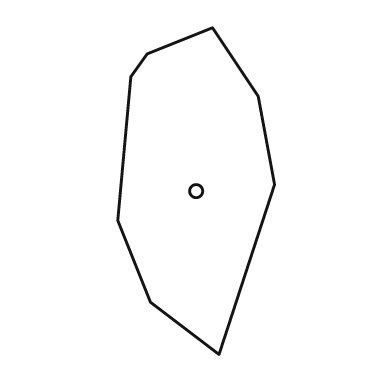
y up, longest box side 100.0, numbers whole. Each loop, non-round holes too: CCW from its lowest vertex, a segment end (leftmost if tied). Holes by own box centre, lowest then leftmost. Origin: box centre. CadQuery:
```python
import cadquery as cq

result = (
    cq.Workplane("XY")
    .moveTo(7.0, -50.0)
    .lineTo(24.0, 2.0)
    .lineTo(19.0, 29.0)
    .lineTo(5.0, 50.0)
    .lineTo(-15.0, 42.0)
    .lineTo(-20.0, 35.0)
    .lineTo(-24.0, -9.0)
    .lineTo(-14.0, -34.0)
    .close()
    .moveTo(0.0, 0.0)
    .circle(2.0)
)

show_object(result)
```